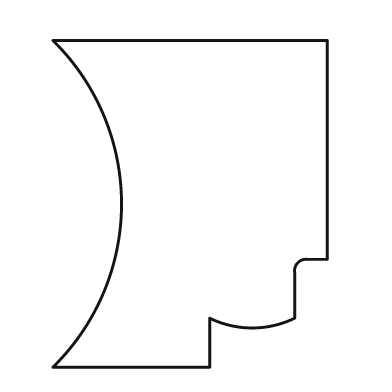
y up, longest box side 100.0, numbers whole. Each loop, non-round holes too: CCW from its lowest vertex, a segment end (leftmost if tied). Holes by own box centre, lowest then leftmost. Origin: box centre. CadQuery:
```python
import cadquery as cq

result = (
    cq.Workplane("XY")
    .moveTo(-42.0, -50.0)
    .lineTo(6.0, -50.0)
    .lineTo(6.0, -35.0)
    .threePointArc((19.0, -38.0), (32.0, -35.0))
    .lineTo(32.0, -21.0)
    .threePointArc((33.0, -18.0), (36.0, -17.0))
    .lineTo(42.0, -17.0)
    .lineTo(42.0, 50.0)
    .lineTo(-42.0, 50.0)
    .threePointArc((-21.0, 0.0), (-42.0, -50.0))
    .close()
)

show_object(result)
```